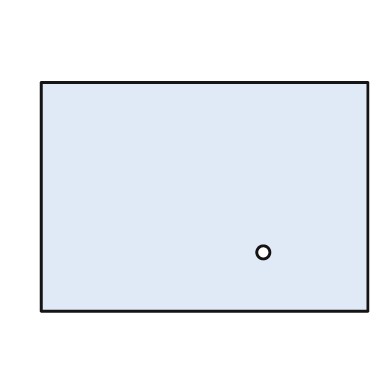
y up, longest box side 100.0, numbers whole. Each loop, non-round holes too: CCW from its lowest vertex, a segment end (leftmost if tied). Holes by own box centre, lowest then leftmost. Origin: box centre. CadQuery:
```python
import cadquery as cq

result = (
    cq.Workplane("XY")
    .moveTo(-50.0, -35.0)
    .lineTo(50.0, -35.0)
    .lineTo(50.0, 35.0)
    .lineTo(-50.0, 35.0)
    .close()
    .moveTo(18.0, -17.0)
    .circle(2.0)
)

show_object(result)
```